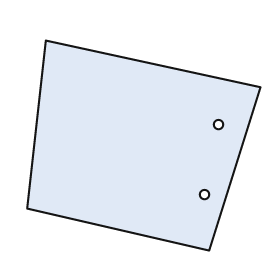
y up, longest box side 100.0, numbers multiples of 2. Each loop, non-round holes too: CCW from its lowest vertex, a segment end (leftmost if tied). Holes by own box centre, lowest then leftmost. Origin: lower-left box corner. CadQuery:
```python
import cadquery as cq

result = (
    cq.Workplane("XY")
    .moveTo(78.0, 0.0)
    .lineTo(100.0, 70.0)
    .lineTo(8.0, 90.0)
    .lineTo(0.0, 18.0)
    .close()
    .moveTo(76.0, 24.0)
    .circle(2.0)
    .moveTo(82.0, 54.0)
    .circle(2.0)
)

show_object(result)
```